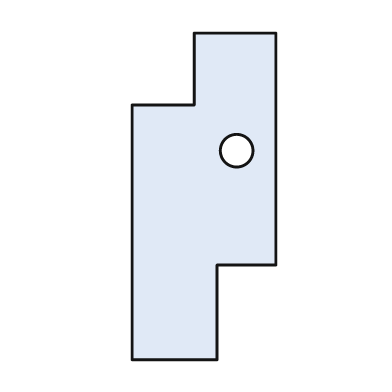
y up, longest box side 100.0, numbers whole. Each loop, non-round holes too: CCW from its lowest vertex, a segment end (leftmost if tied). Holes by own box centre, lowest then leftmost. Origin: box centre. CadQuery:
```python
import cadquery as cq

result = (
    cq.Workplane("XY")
    .moveTo(-22.0, -50.0)
    .lineTo(4.0, -50.0)
    .lineTo(4.0, -21.0)
    .lineTo(22.0, -21.0)
    .lineTo(22.0, 50.0)
    .lineTo(-3.0, 50.0)
    .lineTo(-3.0, 28.0)
    .lineTo(-22.0, 28.0)
    .close()
    .moveTo(10.0, 14.0)
    .circle(5.0)
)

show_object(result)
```